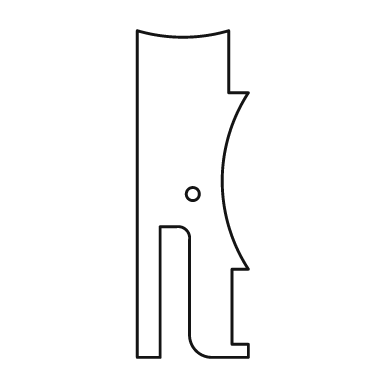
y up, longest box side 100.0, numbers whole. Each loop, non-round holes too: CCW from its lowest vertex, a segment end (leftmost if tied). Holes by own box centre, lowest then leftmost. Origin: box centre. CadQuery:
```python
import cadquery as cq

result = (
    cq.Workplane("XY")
    .moveTo(-17.0, -50.0)
    .lineTo(-10.0, -50.0)
    .lineTo(-10.0, -10.0)
    .lineTo(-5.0, -10.0)
    .threePointArc((-2.0, -11.0), (-1.0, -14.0))
    .lineTo(-1.0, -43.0)
    .threePointArc((1.0, -48.0), (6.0, -50.0))
    .lineTo(17.0, -50.0)
    .lineTo(17.0, -46.0)
    .lineTo(12.0, -46.0)
    .lineTo(12.0, -23.0)
    .lineTo(17.0, -23.0)
    .threePointArc((9.0, 4.0), (17.0, 31.0))
    .lineTo(11.0, 31.0)
    .lineTo(11.0, 50.0)
    .threePointArc((-3.0, 48.0), (-17.0, 50.0))
    .close()
    .moveTo(0.0, 0.0)
    .circle(2.0)
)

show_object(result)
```